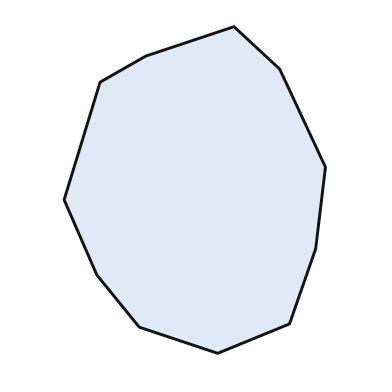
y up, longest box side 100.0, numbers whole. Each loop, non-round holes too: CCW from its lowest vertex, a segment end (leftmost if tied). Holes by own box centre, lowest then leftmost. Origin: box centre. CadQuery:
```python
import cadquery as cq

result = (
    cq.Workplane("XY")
    .moveTo(7.0, -50.0)
    .lineTo(29.0, -41.0)
    .lineTo(37.0, -18.0)
    .lineTo(40.0, 7.0)
    .lineTo(26.0, 37.0)
    .lineTo(12.0, 50.0)
    .lineTo(-15.0, 41.0)
    .lineTo(-29.0, 33.0)
    .lineTo(-40.0, -3.0)
    .lineTo(-30.0, -26.0)
    .lineTo(-17.0, -42.0)
    .close()
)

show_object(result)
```